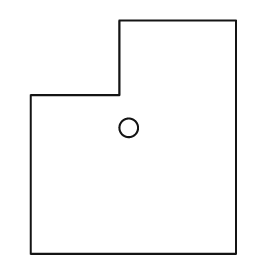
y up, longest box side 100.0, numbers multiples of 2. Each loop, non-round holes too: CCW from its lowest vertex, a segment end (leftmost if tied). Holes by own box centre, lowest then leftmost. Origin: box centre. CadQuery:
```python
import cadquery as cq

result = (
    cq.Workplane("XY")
    .moveTo(-44.0, -50.0)
    .lineTo(44.0, -50.0)
    .lineTo(44.0, 50.0)
    .lineTo(-6.0, 50.0)
    .lineTo(-6.0, 18.0)
    .lineTo(-44.0, 18.0)
    .close()
    .moveTo(-2.0, 4.0)
    .circle(4.0)
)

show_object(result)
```